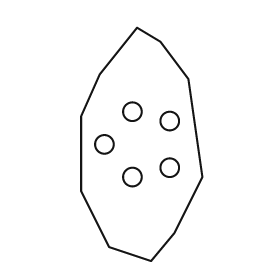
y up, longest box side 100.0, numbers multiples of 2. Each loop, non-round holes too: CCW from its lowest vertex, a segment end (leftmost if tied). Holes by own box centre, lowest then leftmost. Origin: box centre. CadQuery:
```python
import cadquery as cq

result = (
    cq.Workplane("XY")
    .moveTo(4.0, -50.0)
    .lineTo(14.0, -38.0)
    .lineTo(26.0, -14.0)
    .lineTo(20.0, 28.0)
    .lineTo(8.0, 44.0)
    .lineTo(-2.0, 50.0)
    .lineTo(-18.0, 30.0)
    .lineTo(-26.0, 12.0)
    .lineTo(-26.0, -20.0)
    .lineTo(-14.0, -44.0)
    .close()
    .moveTo(-4.0, -14.0)
    .circle(4.0)
    .moveTo(12.0, -10.0)
    .circle(4.0)
    .moveTo(-16.0, 0.0)
    .circle(4.0)
    .moveTo(12.0, 10.0)
    .circle(4.0)
    .moveTo(-4.0, 14.0)
    .circle(4.0)
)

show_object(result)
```